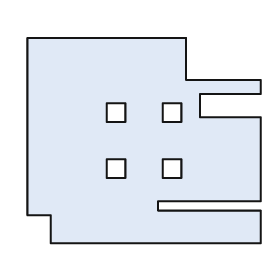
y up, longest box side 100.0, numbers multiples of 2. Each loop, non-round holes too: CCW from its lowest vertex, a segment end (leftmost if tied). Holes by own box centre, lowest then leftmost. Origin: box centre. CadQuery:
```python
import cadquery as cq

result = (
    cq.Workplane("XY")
    .moveTo(-40.0, -44.0)
    .lineTo(50.0, -44.0)
    .lineTo(50.0, -30.0)
    .lineTo(6.0, -30.0)
    .lineTo(6.0, -26.0)
    .lineTo(50.0, -26.0)
    .lineTo(50.0, 10.0)
    .lineTo(24.0, 10.0)
    .lineTo(24.0, 20.0)
    .lineTo(50.0, 20.0)
    .lineTo(50.0, 26.0)
    .lineTo(18.0, 26.0)
    .lineTo(18.0, 44.0)
    .lineTo(-50.0, 44.0)
    .lineTo(-50.0, -32.0)
    .lineTo(-40.0, -32.0)
    .close()
    .moveTo(-16.0, -16.0)
    .lineTo(-8.0, -16.0)
    .lineTo(-8.0, -8.0)
    .lineTo(-16.0, -8.0)
    .close()
    .moveTo(8.0, -16.0)
    .lineTo(16.0, -16.0)
    .lineTo(16.0, -8.0)
    .lineTo(8.0, -8.0)
    .close()
    .moveTo(-16.0, 8.0)
    .lineTo(-8.0, 8.0)
    .lineTo(-8.0, 16.0)
    .lineTo(-16.0, 16.0)
    .close()
    .moveTo(8.0, 8.0)
    .lineTo(16.0, 8.0)
    .lineTo(16.0, 16.0)
    .lineTo(8.0, 16.0)
    .close()
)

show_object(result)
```